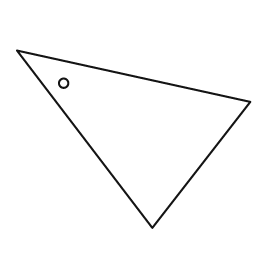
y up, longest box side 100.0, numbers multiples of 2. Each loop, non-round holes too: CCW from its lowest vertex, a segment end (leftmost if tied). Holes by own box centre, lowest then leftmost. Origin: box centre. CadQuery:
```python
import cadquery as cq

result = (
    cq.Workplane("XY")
    .moveTo(8.0, -38.0)
    .lineTo(50.0, 16.0)
    .lineTo(-50.0, 38.0)
    .close()
    .moveTo(-30.0, 24.0)
    .circle(2.0)
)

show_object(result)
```